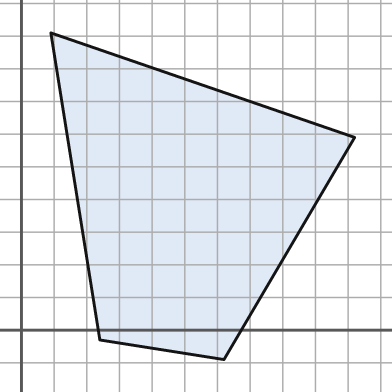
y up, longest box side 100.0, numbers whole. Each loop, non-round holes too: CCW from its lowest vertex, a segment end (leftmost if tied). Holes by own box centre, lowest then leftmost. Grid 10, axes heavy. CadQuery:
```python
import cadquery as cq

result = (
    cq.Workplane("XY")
    .moveTo(62.0, -9.0)
    .lineTo(102.0, 59.0)
    .lineTo(9.0, 91.0)
    .lineTo(24.0, -3.0)
    .close()
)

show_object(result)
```